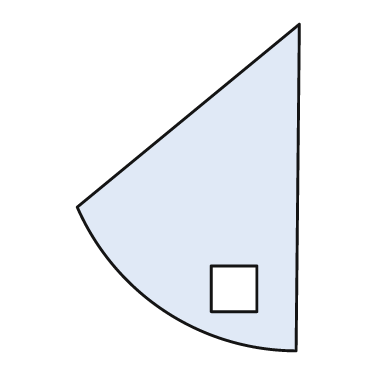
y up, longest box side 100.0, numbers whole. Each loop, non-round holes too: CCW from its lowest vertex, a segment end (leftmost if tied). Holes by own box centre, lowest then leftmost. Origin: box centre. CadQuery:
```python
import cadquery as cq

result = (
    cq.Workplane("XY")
    .moveTo(33.0, -50.0)
    .lineTo(34.0, 50.0)
    .lineTo(-34.0, -6.0)
    .threePointArc((-7.0, -38.0), (33.0, -50.0))
    .close()
    .moveTo(7.0, -38.0)
    .lineTo(21.0, -38.0)
    .lineTo(21.0, -24.0)
    .lineTo(7.0, -24.0)
    .close()
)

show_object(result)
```